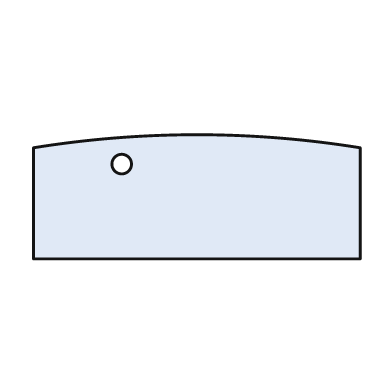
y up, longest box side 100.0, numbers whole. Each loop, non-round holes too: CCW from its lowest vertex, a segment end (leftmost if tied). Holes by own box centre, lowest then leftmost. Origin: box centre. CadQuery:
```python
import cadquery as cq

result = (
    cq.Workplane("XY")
    .moveTo(-50.0, -19.0)
    .lineTo(50.0, -19.0)
    .lineTo(50.0, 15.0)
    .threePointArc((0.0, 19.0), (-50.0, 15.0))
    .close()
    .moveTo(-23.0, 10.0)
    .circle(3.0)
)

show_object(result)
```